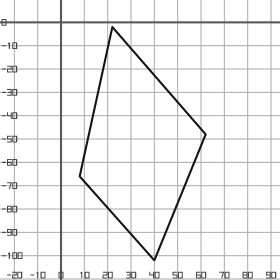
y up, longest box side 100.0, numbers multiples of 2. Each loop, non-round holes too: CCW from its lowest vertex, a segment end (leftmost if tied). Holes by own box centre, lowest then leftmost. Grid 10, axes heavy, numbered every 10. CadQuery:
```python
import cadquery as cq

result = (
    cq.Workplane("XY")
    .moveTo(40.0, -102.0)
    .lineTo(62.0, -48.0)
    .lineTo(22.0, -2.0)
    .lineTo(8.0, -66.0)
    .close()
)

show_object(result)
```